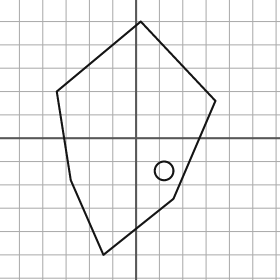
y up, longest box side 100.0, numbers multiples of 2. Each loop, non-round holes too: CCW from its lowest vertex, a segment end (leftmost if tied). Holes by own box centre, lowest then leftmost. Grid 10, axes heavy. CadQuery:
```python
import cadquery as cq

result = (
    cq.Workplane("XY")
    .moveTo(-14.0, -50.0)
    .lineTo(16.0, -26.0)
    .lineTo(34.0, 16.0)
    .lineTo(2.0, 50.0)
    .lineTo(-34.0, 20.0)
    .lineTo(-28.0, -18.0)
    .close()
    .moveTo(12.0, -14.0)
    .circle(4.0)
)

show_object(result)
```